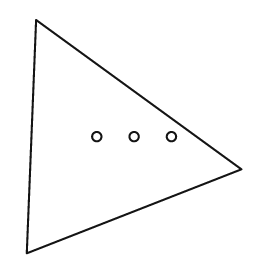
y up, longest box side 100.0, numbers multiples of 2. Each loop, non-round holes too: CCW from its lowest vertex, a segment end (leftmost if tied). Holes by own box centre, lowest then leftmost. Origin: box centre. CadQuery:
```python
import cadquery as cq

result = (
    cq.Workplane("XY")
    .moveTo(-46.0, -50.0)
    .lineTo(46.0, -14.0)
    .lineTo(-42.0, 50.0)
    .close()
    .moveTo(-16.0, 0.0)
    .circle(2.0)
    .moveTo(0.0, 0.0)
    .circle(2.0)
    .moveTo(16.0, 0.0)
    .circle(2.0)
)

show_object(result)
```